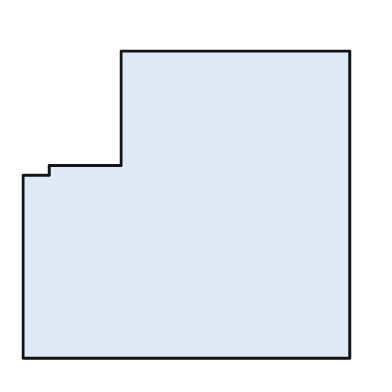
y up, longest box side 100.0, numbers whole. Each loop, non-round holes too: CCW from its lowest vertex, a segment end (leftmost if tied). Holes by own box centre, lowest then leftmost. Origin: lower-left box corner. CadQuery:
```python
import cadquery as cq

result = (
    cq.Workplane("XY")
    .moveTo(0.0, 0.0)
    .lineTo(100.0, 0.0)
    .lineTo(100.0, 94.0)
    .lineTo(30.0, 94.0)
    .lineTo(30.0, 59.0)
    .lineTo(8.0, 59.0)
    .lineTo(8.0, 56.0)
    .lineTo(0.0, 56.0)
    .close()
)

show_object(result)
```